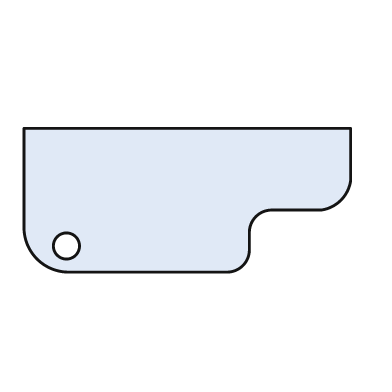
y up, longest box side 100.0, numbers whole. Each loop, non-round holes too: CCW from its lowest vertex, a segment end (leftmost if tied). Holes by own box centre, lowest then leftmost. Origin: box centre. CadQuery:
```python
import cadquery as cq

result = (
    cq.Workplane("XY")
    .moveTo(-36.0, -22.0)
    .lineTo(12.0, -22.0)
    .threePointArc((17.0, -20.0), (19.0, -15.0))
    .lineTo(19.0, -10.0)
    .threePointArc((21.0, -5.0), (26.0, -3.0))
    .lineTo(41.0, -3.0)
    .threePointArc((47.0, 0.0), (50.0, 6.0))
    .lineTo(50.0, 22.0)
    .lineTo(-50.0, 22.0)
    .lineTo(-50.0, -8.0)
    .threePointArc((-46.0, -18.0), (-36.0, -22.0))
    .close()
    .moveTo(-37.0, -14.0)
    .circle(4.0)
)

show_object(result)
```